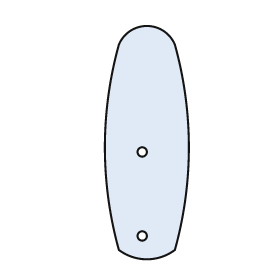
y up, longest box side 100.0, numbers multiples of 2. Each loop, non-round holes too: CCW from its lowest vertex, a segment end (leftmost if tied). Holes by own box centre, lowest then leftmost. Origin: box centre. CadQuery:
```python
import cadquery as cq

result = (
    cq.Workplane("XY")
    .moveTo(-12.0, -46.0)
    .threePointArc((0.0, -50.0), (12.0, -46.0))
    .threePointArc((18.0, -2.0), (12.0, 42.0))
    .threePointArc((0.0, 50.0), (-12.0, 42.0))
    .threePointArc((-18.0, -2.0), (-12.0, -46.0))
    .close()
    .moveTo(-2.0, -40.0)
    .circle(2.0)
    .moveTo(-2.0, -4.0)
    .circle(2.0)
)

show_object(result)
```